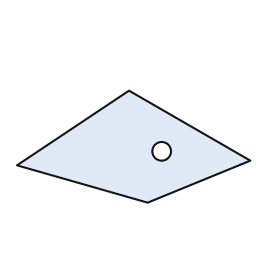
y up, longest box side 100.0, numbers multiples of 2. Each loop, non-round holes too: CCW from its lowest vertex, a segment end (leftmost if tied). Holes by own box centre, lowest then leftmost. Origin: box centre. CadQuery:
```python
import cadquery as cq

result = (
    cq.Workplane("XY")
    .moveTo(6.0, -24.0)
    .lineTo(50.0, -6.0)
    .lineTo(-2.0, 24.0)
    .lineTo(-50.0, -8.0)
    .close()
    .moveTo(12.0, -2.0)
    .circle(4.0)
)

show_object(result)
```